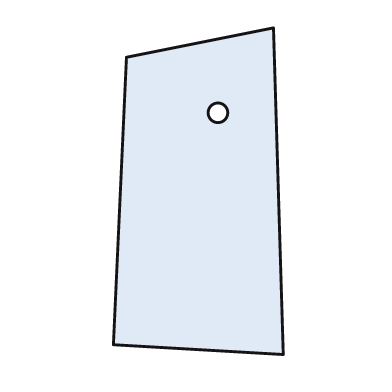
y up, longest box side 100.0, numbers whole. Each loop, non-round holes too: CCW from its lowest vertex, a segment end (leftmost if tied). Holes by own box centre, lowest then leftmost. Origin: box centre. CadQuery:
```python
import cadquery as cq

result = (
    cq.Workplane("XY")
    .moveTo(26.0, -50.0)
    .lineTo(23.0, 50.0)
    .lineTo(-22.0, 41.0)
    .lineTo(-26.0, -47.0)
    .close()
    .moveTo(6.0, 24.0)
    .circle(3.0)
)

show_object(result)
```